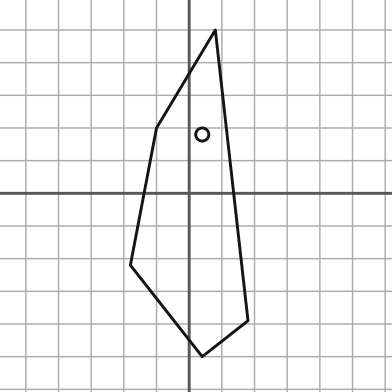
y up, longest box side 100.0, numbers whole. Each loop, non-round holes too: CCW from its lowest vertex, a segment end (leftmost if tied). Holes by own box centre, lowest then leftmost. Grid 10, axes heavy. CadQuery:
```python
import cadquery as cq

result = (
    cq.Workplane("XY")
    .moveTo(4.0, -50.0)
    .lineTo(18.0, -39.0)
    .lineTo(8.0, 50.0)
    .lineTo(-10.0, 20.0)
    .lineTo(-18.0, -22.0)
    .close()
    .moveTo(4.0, 18.0)
    .circle(2.0)
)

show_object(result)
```